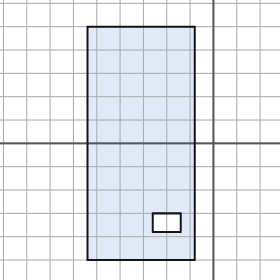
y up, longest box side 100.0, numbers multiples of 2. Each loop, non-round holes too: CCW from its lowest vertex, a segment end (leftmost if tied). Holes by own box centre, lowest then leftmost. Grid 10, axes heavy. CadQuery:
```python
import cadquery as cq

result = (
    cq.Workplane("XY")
    .moveTo(-54.0, -50.0)
    .lineTo(-8.0, -50.0)
    .lineTo(-8.0, 50.0)
    .lineTo(-54.0, 50.0)
    .close()
    .moveTo(-26.0, -38.0)
    .lineTo(-14.0, -38.0)
    .lineTo(-14.0, -30.0)
    .lineTo(-26.0, -30.0)
    .close()
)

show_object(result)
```